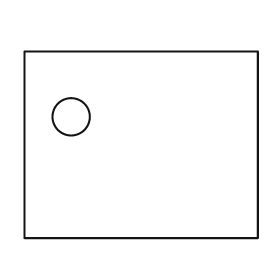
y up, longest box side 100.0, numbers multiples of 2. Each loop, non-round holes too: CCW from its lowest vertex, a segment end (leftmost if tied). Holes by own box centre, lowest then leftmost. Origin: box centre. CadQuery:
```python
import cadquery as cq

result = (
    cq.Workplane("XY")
    .moveTo(-50.0, -40.0)
    .lineTo(50.0, -40.0)
    .lineTo(50.0, 40.0)
    .lineTo(-50.0, 40.0)
    .close()
    .moveTo(-30.0, 12.0)
    .circle(8.0)
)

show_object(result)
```